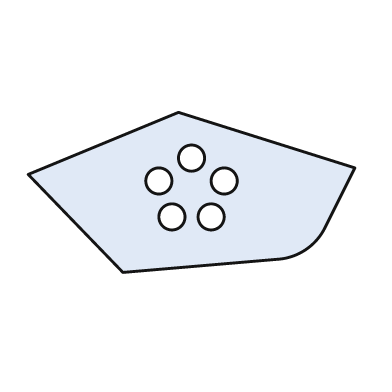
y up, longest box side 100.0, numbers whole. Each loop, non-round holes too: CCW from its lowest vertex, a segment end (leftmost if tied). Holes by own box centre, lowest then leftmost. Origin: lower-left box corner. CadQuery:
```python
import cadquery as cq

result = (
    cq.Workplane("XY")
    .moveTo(29.0, 0.0)
    .lineTo(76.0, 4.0)
    .threePointArc((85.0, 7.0), (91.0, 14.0))
    .lineTo(100.0, 32.0)
    .lineTo(46.0, 49.0)
    .lineTo(0.0, 30.0)
    .close()
    .moveTo(44.0, 17.0)
    .circle(4.0)
    .moveTo(56.0, 17.0)
    .circle(4.0)
    .moveTo(40.0, 28.0)
    .circle(4.0)
    .moveTo(60.0, 28.0)
    .circle(4.0)
    .moveTo(50.0, 35.0)
    .circle(4.0)
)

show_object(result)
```